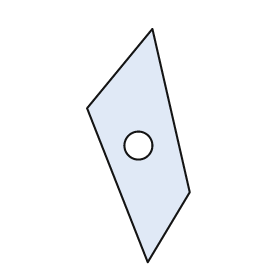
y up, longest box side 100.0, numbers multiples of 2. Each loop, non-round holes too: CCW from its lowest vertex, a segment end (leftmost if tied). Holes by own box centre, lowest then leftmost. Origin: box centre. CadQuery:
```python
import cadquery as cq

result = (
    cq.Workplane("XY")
    .moveTo(4.0, -50.0)
    .lineTo(22.0, -20.0)
    .lineTo(6.0, 50.0)
    .lineTo(-22.0, 16.0)
    .close()
    .moveTo(0.0, 0.0)
    .circle(6.0)
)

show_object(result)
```